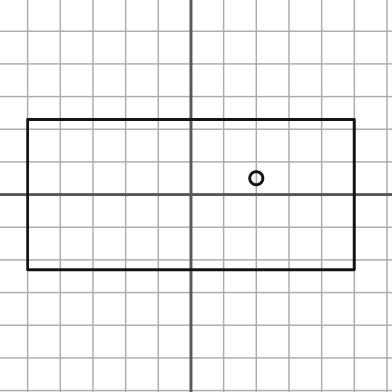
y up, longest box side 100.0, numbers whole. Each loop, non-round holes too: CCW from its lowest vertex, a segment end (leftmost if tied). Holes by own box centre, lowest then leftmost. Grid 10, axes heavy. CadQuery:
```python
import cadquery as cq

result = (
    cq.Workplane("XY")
    .moveTo(-50.0, -23.0)
    .lineTo(50.0, -23.0)
    .lineTo(50.0, 23.0)
    .lineTo(-50.0, 23.0)
    .close()
    .moveTo(20.0, 5.0)
    .circle(2.0)
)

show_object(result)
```